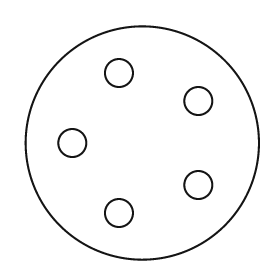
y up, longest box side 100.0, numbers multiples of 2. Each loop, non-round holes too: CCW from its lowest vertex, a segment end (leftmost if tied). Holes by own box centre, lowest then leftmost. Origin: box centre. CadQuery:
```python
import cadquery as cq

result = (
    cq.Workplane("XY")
    .moveTo(0.0, 0.0)
    .circle(50.0)
    .moveTo(-10.0, -30.0)
    .circle(6.0)
    .moveTo(24.0, -18.0)
    .circle(6.0)
    .moveTo(-30.0, 0.0)
    .circle(6.0)
    .moveTo(24.0, 18.0)
    .circle(6.0)
    .moveTo(-10.0, 30.0)
    .circle(6.0)
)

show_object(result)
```